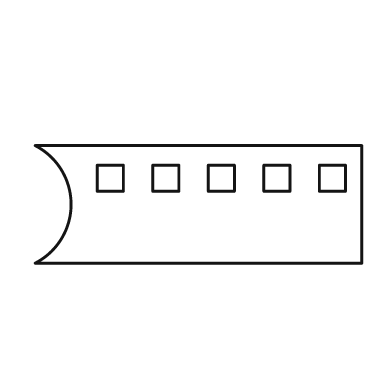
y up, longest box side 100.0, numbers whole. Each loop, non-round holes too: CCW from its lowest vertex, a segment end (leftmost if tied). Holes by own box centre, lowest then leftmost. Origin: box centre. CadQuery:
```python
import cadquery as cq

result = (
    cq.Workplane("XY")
    .moveTo(-50.0, -18.0)
    .lineTo(50.0, -18.0)
    .lineTo(50.0, 18.0)
    .lineTo(-50.0, 18.0)
    .threePointArc((-39.0, 0.0), (-50.0, -18.0))
    .close()
    .moveTo(-31.0, 4.0)
    .lineTo(-23.0, 4.0)
    .lineTo(-23.0, 12.0)
    .lineTo(-31.0, 12.0)
    .close()
    .moveTo(-14.0, 4.0)
    .lineTo(-6.0, 4.0)
    .lineTo(-6.0, 12.0)
    .lineTo(-14.0, 12.0)
    .close()
    .moveTo(3.0, 4.0)
    .lineTo(11.0, 4.0)
    .lineTo(11.0, 12.0)
    .lineTo(3.0, 12.0)
    .close()
    .moveTo(20.0, 4.0)
    .lineTo(28.0, 4.0)
    .lineTo(28.0, 12.0)
    .lineTo(20.0, 12.0)
    .close()
    .moveTo(37.0, 4.0)
    .lineTo(45.0, 4.0)
    .lineTo(45.0, 12.0)
    .lineTo(37.0, 12.0)
    .close()
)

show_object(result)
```